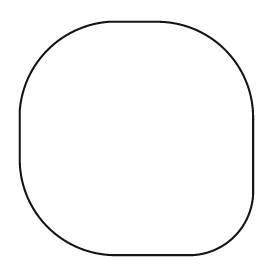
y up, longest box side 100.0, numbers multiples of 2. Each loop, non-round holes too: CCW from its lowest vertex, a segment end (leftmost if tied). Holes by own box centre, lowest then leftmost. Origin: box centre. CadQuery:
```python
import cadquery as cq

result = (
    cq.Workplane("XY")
    .moveTo(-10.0, -50.0)
    .lineTo(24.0, -50.0)
    .threePointArc((42.0, -42.0), (50.0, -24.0))
    .lineTo(50.0, 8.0)
    .threePointArc((38.0, 38.0), (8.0, 50.0))
    .lineTo(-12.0, 50.0)
    .threePointArc((-38.0, 38.0), (-50.0, 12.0))
    .lineTo(-50.0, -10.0)
    .threePointArc((-38.0, -38.0), (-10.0, -50.0))
    .close()
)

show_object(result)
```